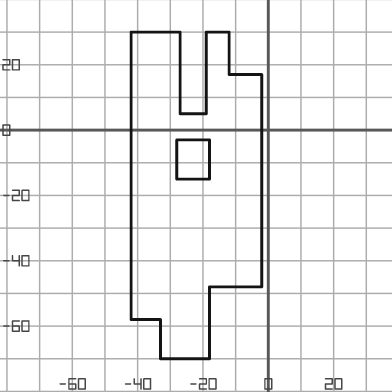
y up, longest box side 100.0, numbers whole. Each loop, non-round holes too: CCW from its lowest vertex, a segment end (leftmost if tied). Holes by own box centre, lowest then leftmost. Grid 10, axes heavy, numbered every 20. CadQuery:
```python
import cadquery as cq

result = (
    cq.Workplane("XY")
    .moveTo(-33.0, -70.0)
    .lineTo(-18.0, -70.0)
    .lineTo(-18.0, -48.0)
    .lineTo(-2.0, -48.0)
    .lineTo(-2.0, 17.0)
    .lineTo(-12.0, 17.0)
    .lineTo(-12.0, 30.0)
    .lineTo(-19.0, 30.0)
    .lineTo(-19.0, 5.0)
    .lineTo(-27.0, 5.0)
    .lineTo(-27.0, 30.0)
    .lineTo(-42.0, 30.0)
    .lineTo(-42.0, -58.0)
    .lineTo(-33.0, -58.0)
    .close()
    .moveTo(-28.0, -15.0)
    .lineTo(-18.0, -15.0)
    .lineTo(-18.0, -3.0)
    .lineTo(-28.0, -3.0)
    .close()
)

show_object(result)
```